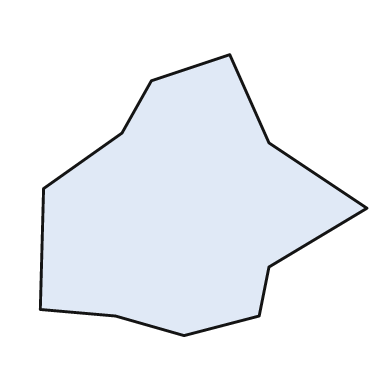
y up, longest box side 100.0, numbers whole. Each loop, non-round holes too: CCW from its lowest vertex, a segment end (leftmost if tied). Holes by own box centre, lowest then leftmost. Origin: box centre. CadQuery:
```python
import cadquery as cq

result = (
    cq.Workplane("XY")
    .moveTo(-6.0, -43.0)
    .lineTo(17.0, -37.0)
    .lineTo(20.0, -22.0)
    .lineTo(50.0, -4.0)
    .lineTo(20.0, 16.0)
    .lineTo(8.0, 43.0)
    .lineTo(-16.0, 35.0)
    .lineTo(-25.0, 19.0)
    .lineTo(-49.0, 2.0)
    .lineTo(-50.0, -35.0)
    .lineTo(-27.0, -37.0)
    .close()
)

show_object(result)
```